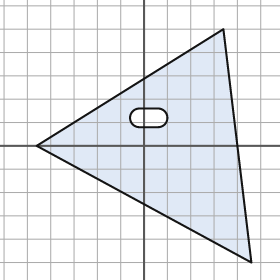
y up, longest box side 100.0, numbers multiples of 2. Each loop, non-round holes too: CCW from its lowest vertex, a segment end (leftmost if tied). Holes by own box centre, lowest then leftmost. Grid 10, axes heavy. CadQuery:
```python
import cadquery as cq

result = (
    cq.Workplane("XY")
    .moveTo(46.0, -50.0)
    .lineTo(34.0, 50.0)
    .lineTo(-46.0, 0.0)
    .close()
    .moveTo(-2.0, 8.0)
    .lineTo(6.0, 8.0)
    .threePointArc((10.0, 12.0), (6.0, 16.0))
    .lineTo(-2.0, 16.0)
    .threePointArc((-6.0, 12.0), (-2.0, 8.0))
    .close()
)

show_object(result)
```